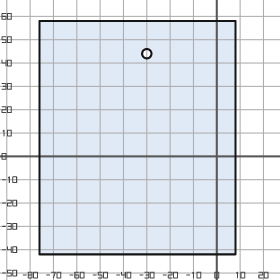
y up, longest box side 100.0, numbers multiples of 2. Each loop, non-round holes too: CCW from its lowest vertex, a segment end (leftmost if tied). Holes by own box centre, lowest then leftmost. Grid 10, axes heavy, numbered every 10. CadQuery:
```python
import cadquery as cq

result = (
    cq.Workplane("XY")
    .moveTo(-76.0, -42.0)
    .lineTo(8.0, -42.0)
    .lineTo(8.0, 58.0)
    .lineTo(-76.0, 58.0)
    .close()
    .moveTo(-30.0, 44.0)
    .circle(2.0)
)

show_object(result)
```